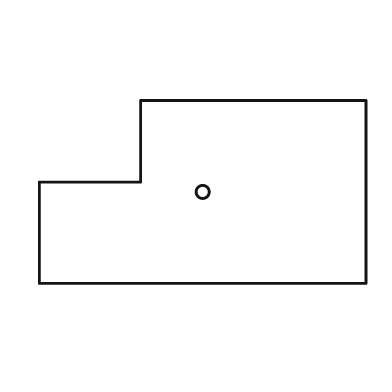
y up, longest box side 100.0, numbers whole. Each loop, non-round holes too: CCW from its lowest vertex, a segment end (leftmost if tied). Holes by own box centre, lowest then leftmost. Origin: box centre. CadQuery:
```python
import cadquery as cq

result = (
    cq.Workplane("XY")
    .moveTo(-50.0, -28.0)
    .lineTo(50.0, -28.0)
    .lineTo(50.0, 28.0)
    .lineTo(-19.0, 28.0)
    .lineTo(-19.0, 3.0)
    .lineTo(-50.0, 3.0)
    .close()
    .moveTo(0.0, 0.0)
    .circle(2.0)
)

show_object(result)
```